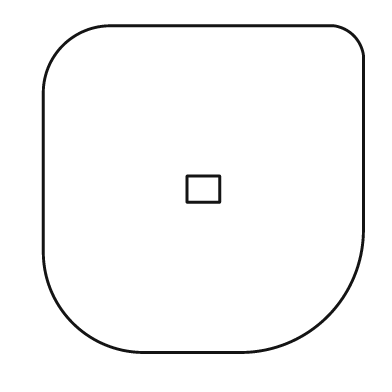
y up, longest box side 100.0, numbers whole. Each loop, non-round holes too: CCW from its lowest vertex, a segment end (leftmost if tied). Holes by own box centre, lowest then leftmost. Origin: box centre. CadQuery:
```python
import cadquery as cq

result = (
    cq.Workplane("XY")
    .moveTo(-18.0, -50.0)
    .lineTo(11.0, -50.0)
    .threePointArc((38.0, -39.0), (49.0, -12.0))
    .lineTo(49.0, 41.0)
    .threePointArc((46.0, 47.0), (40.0, 50.0))
    .lineTo(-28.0, 50.0)
    .threePointArc((-43.0, 44.0), (-49.0, 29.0))
    .lineTo(-49.0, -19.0)
    .threePointArc((-40.0, -41.0), (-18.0, -50.0))
    .close()
    .moveTo(-5.0, -4.0)
    .lineTo(5.0, -4.0)
    .lineTo(5.0, 4.0)
    .lineTo(-5.0, 4.0)
    .close()
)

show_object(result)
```